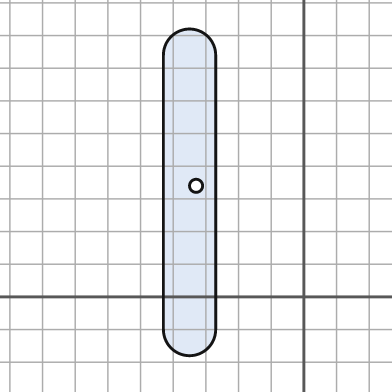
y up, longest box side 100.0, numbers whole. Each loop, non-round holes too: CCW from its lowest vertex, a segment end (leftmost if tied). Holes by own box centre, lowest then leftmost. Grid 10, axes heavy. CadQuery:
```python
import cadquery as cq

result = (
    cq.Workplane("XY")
    .moveTo(-43.0, -10.0)
    .threePointArc((-35.0, -18.0), (-27.0, -10.0))
    .lineTo(-27.0, 74.0)
    .threePointArc((-35.0, 82.0), (-43.0, 74.0))
    .close()
    .moveTo(-33.0, 34.0)
    .circle(2.0)
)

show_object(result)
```